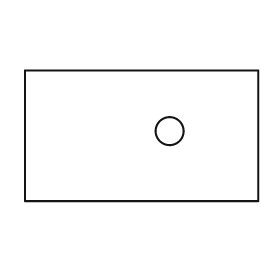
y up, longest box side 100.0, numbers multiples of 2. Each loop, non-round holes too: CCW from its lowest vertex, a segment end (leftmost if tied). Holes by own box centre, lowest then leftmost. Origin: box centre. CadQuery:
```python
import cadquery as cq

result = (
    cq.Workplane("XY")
    .moveTo(-50.0, -28.0)
    .lineTo(50.0, -28.0)
    .lineTo(50.0, 28.0)
    .lineTo(-50.0, 28.0)
    .close()
    .moveTo(12.0, 2.0)
    .circle(6.0)
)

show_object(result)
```